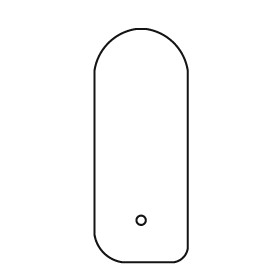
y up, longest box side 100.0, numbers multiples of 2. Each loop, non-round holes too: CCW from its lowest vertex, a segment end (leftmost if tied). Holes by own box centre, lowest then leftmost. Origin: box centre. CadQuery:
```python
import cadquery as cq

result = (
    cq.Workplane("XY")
    .moveTo(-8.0, -50.0)
    .lineTo(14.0, -50.0)
    .threePointArc((18.0, -48.0), (20.0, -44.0))
    .lineTo(20.0, 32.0)
    .threePointArc((14.0, 44.0), (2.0, 50.0))
    .lineTo(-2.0, 50.0)
    .threePointArc((-14.0, 44.0), (-20.0, 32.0))
    .lineTo(-20.0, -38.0)
    .threePointArc((-16.0, -46.0), (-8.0, -50.0))
    .close()
    .moveTo(0.0, -32.0)
    .circle(2.0)
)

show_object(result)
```